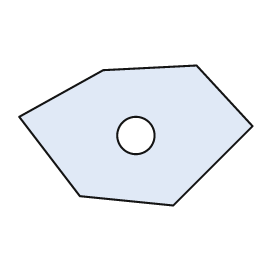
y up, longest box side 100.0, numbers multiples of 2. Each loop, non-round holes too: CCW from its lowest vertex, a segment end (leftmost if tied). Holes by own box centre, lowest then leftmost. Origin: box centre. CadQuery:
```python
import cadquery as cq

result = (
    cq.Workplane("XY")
    .moveTo(16.0, -30.0)
    .lineTo(50.0, 4.0)
    .lineTo(26.0, 30.0)
    .lineTo(-14.0, 28.0)
    .lineTo(-50.0, 8.0)
    .lineTo(-24.0, -26.0)
    .close()
    .moveTo(0.0, 0.0)
    .circle(8.0)
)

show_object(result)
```